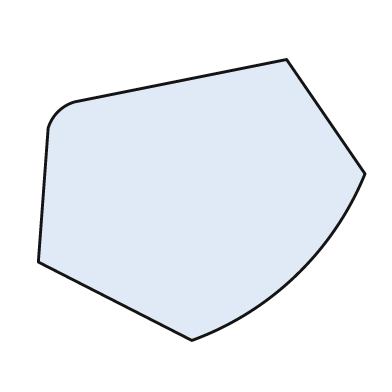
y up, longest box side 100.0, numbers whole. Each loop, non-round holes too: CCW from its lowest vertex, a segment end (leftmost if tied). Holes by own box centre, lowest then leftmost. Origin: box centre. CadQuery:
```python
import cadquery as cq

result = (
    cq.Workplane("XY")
    .moveTo(-3.0, -43.0)
    .threePointArc((29.0, -23.0), (50.0, 8.0))
    .lineTo(26.0, 43.0)
    .lineTo(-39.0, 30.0)
    .threePointArc((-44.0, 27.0), (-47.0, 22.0))
    .lineTo(-50.0, -19.0)
    .close()
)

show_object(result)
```